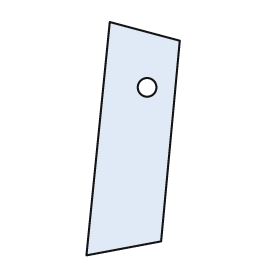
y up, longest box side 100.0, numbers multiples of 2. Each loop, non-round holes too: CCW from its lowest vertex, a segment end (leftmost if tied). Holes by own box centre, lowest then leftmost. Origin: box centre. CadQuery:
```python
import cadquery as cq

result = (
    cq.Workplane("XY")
    .moveTo(-20.0, -50.0)
    .lineTo(12.0, -44.0)
    .lineTo(20.0, 42.0)
    .lineTo(-10.0, 50.0)
    .close()
    .moveTo(6.0, 22.0)
    .circle(4.0)
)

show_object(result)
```